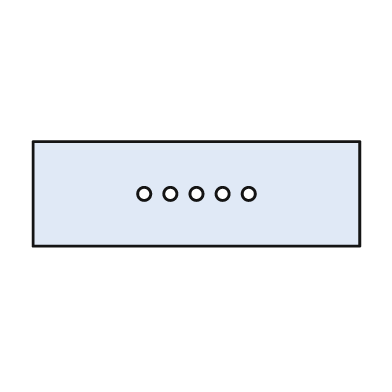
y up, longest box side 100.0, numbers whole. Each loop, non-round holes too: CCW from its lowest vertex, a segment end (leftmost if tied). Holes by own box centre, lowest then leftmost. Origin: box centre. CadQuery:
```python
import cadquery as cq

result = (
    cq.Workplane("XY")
    .moveTo(-50.0, -16.0)
    .lineTo(50.0, -16.0)
    .lineTo(50.0, 16.0)
    .lineTo(-50.0, 16.0)
    .close()
    .moveTo(-16.0, 0.0)
    .circle(2.0)
    .moveTo(-8.0, 0.0)
    .circle(2.0)
    .moveTo(0.0, 0.0)
    .circle(2.0)
    .moveTo(8.0, 0.0)
    .circle(2.0)
    .moveTo(16.0, 0.0)
    .circle(2.0)
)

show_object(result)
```